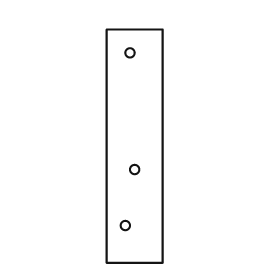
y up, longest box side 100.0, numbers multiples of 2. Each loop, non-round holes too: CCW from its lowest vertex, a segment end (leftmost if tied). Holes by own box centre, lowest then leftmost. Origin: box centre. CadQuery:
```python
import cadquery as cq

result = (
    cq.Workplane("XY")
    .moveTo(-12.0, -50.0)
    .lineTo(12.0, -50.0)
    .lineTo(12.0, 50.0)
    .lineTo(-12.0, 50.0)
    .close()
    .moveTo(-4.0, -34.0)
    .circle(2.0)
    .moveTo(0.0, -10.0)
    .circle(2.0)
    .moveTo(-2.0, 40.0)
    .circle(2.0)
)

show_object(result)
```